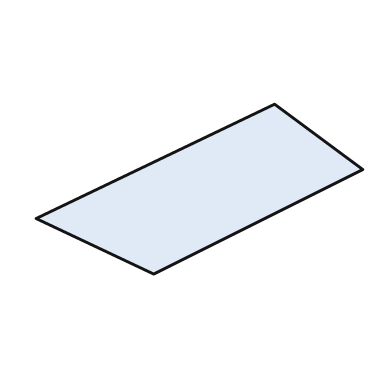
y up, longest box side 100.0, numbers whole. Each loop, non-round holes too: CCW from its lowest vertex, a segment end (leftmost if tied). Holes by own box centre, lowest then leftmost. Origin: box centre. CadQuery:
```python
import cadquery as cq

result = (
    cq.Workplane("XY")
    .moveTo(-14.0, -26.0)
    .lineTo(50.0, 6.0)
    .lineTo(23.0, 26.0)
    .lineTo(-50.0, -9.0)
    .close()
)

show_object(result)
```